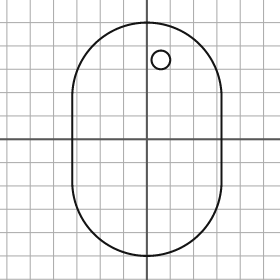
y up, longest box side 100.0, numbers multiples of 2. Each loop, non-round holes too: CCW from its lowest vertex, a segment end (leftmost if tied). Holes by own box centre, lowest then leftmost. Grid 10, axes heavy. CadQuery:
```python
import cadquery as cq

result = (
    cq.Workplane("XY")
    .moveTo(-32.0, -18.0)
    .threePointArc((0.0, -50.0), (32.0, -18.0))
    .lineTo(32.0, 18.0)
    .threePointArc((0.0, 50.0), (-32.0, 18.0))
    .close()
    .moveTo(6.0, 34.0)
    .circle(4.0)
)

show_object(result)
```